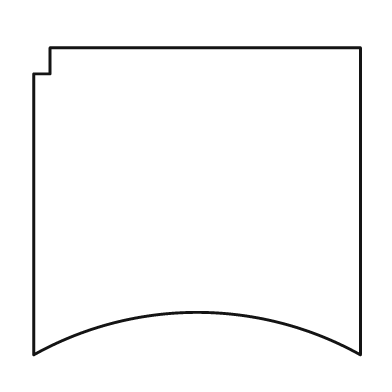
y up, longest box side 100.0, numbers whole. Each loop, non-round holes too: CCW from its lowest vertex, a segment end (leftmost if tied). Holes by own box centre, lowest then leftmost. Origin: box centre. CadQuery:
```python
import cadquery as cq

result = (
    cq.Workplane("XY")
    .moveTo(-50.0, -47.0)
    .threePointArc((0.0, -34.0), (50.0, -47.0))
    .lineTo(50.0, 47.0)
    .lineTo(-45.0, 47.0)
    .lineTo(-45.0, 39.0)
    .lineTo(-50.0, 39.0)
    .close()
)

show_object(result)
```